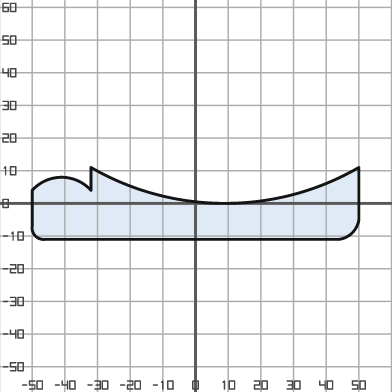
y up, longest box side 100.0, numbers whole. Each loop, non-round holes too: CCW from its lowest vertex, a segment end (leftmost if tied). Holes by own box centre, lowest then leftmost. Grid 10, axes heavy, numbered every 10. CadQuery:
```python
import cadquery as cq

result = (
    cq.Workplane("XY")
    .moveTo(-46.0, -11.0)
    .lineTo(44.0, -11.0)
    .threePointArc((48.0, -9.0), (50.0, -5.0))
    .lineTo(50.0, 11.0)
    .threePointArc((9.0, 0.0), (-32.0, 11.0))
    .lineTo(-32.0, 4.0)
    .threePointArc((-41.0, 8.0), (-50.0, 4.0))
    .lineTo(-50.0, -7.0)
    .threePointArc((-49.0, -10.0), (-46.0, -11.0))
    .close()
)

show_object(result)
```